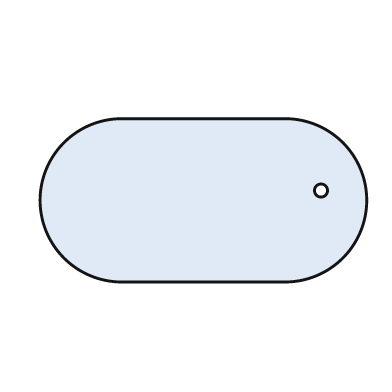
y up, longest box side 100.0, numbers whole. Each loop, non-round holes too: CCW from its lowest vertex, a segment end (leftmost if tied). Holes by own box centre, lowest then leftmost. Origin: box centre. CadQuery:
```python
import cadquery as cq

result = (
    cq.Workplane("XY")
    .moveTo(-25.0, -25.0)
    .lineTo(25.0, -25.0)
    .threePointArc((50.0, 0.0), (25.0, 25.0))
    .lineTo(-25.0, 25.0)
    .threePointArc((-50.0, 0.0), (-25.0, -25.0))
    .close()
    .moveTo(36.0, 3.0)
    .circle(2.0)
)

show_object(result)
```